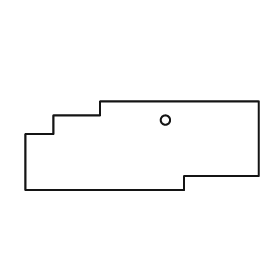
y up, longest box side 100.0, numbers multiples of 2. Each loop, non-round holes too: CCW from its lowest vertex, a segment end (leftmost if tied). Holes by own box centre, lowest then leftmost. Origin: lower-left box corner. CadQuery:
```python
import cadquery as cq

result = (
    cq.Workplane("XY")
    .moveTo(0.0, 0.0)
    .lineTo(68.0, 0.0)
    .lineTo(68.0, 6.0)
    .lineTo(100.0, 6.0)
    .lineTo(100.0, 38.0)
    .lineTo(32.0, 38.0)
    .lineTo(32.0, 32.0)
    .lineTo(12.0, 32.0)
    .lineTo(12.0, 24.0)
    .lineTo(0.0, 24.0)
    .close()
    .moveTo(60.0, 30.0)
    .circle(2.0)
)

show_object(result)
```